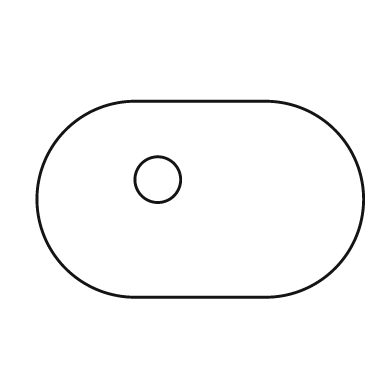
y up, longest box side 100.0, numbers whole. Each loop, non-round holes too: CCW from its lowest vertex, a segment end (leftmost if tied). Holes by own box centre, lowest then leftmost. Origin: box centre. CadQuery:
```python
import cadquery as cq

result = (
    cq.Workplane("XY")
    .moveTo(-20.0, -30.0)
    .lineTo(20.0, -30.0)
    .threePointArc((50.0, 0.0), (20.0, 30.0))
    .lineTo(-20.0, 30.0)
    .threePointArc((-50.0, 0.0), (-20.0, -30.0))
    .close()
    .moveTo(-13.0, 6.0)
    .circle(7.0)
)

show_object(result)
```